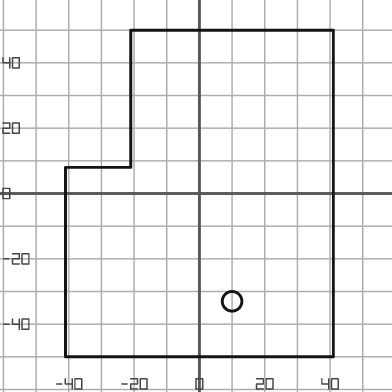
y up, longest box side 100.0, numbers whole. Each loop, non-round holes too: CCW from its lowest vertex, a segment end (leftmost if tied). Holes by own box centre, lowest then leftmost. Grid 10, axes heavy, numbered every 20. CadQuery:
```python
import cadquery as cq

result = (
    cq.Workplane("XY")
    .moveTo(-41.0, -50.0)
    .lineTo(41.0, -50.0)
    .lineTo(41.0, 50.0)
    .lineTo(-21.0, 50.0)
    .lineTo(-21.0, 8.0)
    .lineTo(-41.0, 8.0)
    .close()
    .moveTo(10.0, -33.0)
    .circle(3.0)
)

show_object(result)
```